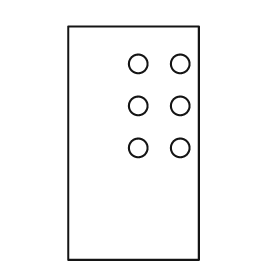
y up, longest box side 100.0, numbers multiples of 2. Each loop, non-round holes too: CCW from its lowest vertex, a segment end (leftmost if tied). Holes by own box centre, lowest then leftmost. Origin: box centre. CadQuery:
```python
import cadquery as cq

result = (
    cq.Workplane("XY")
    .moveTo(-28.0, -50.0)
    .lineTo(28.0, -50.0)
    .lineTo(28.0, 50.0)
    .lineTo(-28.0, 50.0)
    .close()
    .moveTo(2.0, -2.0)
    .circle(4.0)
    .moveTo(20.0, -2.0)
    .circle(4.0)
    .moveTo(2.0, 16.0)
    .circle(4.0)
    .moveTo(20.0, 16.0)
    .circle(4.0)
    .moveTo(2.0, 34.0)
    .circle(4.0)
    .moveTo(20.0, 34.0)
    .circle(4.0)
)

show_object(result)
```